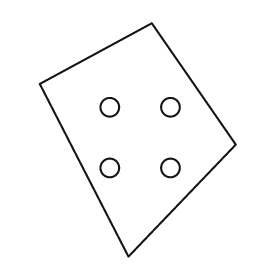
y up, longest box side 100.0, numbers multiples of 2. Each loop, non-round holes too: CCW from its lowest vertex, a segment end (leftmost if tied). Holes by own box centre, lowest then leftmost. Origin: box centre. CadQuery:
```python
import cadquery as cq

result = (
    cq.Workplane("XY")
    .moveTo(-4.0, -50.0)
    .lineTo(42.0, -2.0)
    .lineTo(6.0, 50.0)
    .lineTo(-42.0, 24.0)
    .close()
    .moveTo(-12.0, -12.0)
    .circle(4.0)
    .moveTo(14.0, -12.0)
    .circle(4.0)
    .moveTo(-12.0, 14.0)
    .circle(4.0)
    .moveTo(14.0, 14.0)
    .circle(4.0)
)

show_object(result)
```